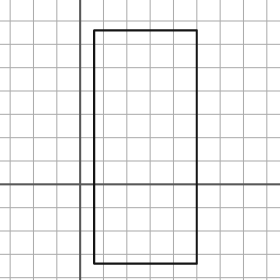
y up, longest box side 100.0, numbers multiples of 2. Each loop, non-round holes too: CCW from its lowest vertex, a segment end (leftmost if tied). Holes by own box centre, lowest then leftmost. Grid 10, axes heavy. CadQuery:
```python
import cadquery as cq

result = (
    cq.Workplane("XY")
    .moveTo(6.0, -34.0)
    .lineTo(50.0, -34.0)
    .lineTo(50.0, 66.0)
    .lineTo(6.0, 66.0)
    .close()
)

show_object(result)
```